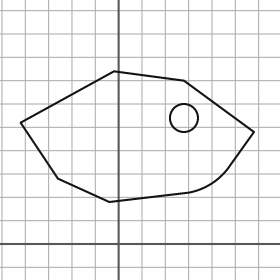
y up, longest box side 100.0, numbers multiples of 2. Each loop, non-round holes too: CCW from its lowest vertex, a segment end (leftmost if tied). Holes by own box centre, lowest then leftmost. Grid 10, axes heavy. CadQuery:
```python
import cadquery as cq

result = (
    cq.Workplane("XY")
    .moveTo(-4.0, 18.0)
    .lineTo(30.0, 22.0)
    .threePointArc((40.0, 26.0), (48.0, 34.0))
    .lineTo(58.0, 48.0)
    .lineTo(28.0, 70.0)
    .lineTo(-2.0, 74.0)
    .lineTo(-42.0, 52.0)
    .lineTo(-26.0, 28.0)
    .close()
    .moveTo(28.0, 54.0)
    .circle(6.0)
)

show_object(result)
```